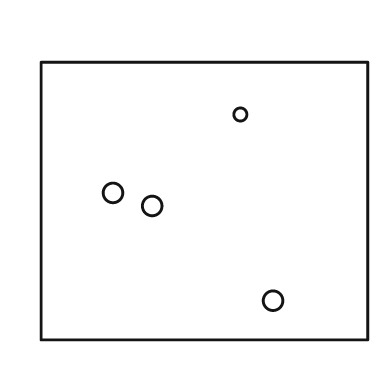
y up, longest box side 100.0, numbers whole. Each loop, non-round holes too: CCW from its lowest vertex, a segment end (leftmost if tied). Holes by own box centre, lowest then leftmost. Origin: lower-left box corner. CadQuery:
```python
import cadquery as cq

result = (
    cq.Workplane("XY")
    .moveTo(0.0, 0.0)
    .lineTo(100.0, 0.0)
    .lineTo(100.0, 85.0)
    .lineTo(0.0, 85.0)
    .close()
    .moveTo(71.0, 12.0)
    .circle(3.0)
    .moveTo(34.0, 41.0)
    .circle(3.0)
    .moveTo(22.0, 45.0)
    .circle(3.0)
    .moveTo(61.0, 69.0)
    .circle(2.0)
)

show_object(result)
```